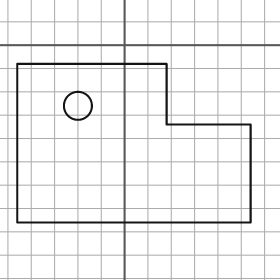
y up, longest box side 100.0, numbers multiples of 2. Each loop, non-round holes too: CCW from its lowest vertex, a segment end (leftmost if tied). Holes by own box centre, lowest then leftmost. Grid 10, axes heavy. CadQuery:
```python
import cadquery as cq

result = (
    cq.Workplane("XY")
    .moveTo(-46.0, -76.0)
    .lineTo(54.0, -76.0)
    .lineTo(54.0, -34.0)
    .lineTo(18.0, -34.0)
    .lineTo(18.0, -8.0)
    .lineTo(-46.0, -8.0)
    .close()
    .moveTo(-20.0, -26.0)
    .circle(6.0)
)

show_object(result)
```